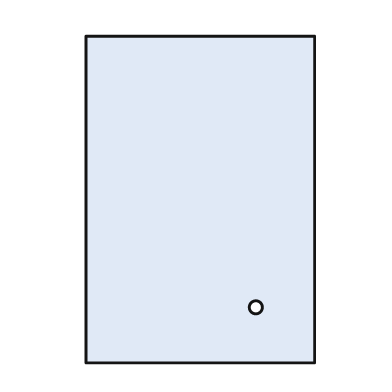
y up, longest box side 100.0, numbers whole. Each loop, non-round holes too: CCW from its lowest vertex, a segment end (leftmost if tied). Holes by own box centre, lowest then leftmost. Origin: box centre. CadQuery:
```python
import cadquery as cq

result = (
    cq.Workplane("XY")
    .moveTo(-35.0, -50.0)
    .lineTo(35.0, -50.0)
    .lineTo(35.0, 50.0)
    .lineTo(-35.0, 50.0)
    .close()
    .moveTo(17.0, -33.0)
    .circle(2.0)
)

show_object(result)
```